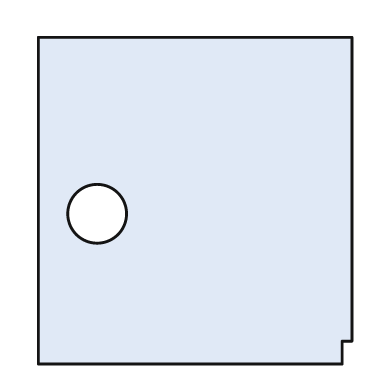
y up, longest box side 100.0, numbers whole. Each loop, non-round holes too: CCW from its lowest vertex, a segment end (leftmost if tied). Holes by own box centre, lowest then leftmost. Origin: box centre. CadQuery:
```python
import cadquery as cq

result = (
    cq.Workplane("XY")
    .moveTo(-48.0, -50.0)
    .lineTo(45.0, -50.0)
    .lineTo(45.0, -43.0)
    .lineTo(48.0, -43.0)
    .lineTo(48.0, 50.0)
    .lineTo(-48.0, 50.0)
    .close()
    .moveTo(-30.0, -4.0)
    .circle(9.0)
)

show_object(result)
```